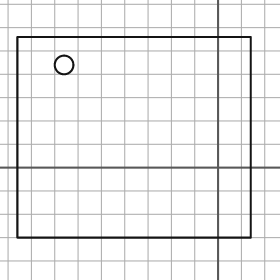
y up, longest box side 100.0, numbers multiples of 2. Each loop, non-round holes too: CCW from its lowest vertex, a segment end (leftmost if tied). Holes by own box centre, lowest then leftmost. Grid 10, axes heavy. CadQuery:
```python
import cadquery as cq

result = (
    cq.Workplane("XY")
    .moveTo(-86.0, -30.0)
    .lineTo(14.0, -30.0)
    .lineTo(14.0, 56.0)
    .lineTo(-86.0, 56.0)
    .close()
    .moveTo(-66.0, 44.0)
    .circle(4.0)
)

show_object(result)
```